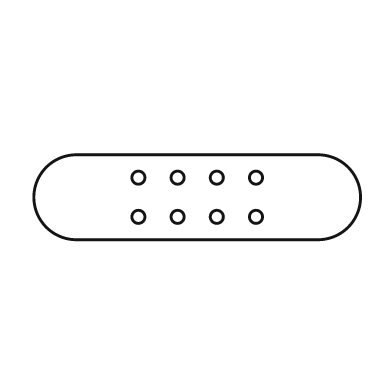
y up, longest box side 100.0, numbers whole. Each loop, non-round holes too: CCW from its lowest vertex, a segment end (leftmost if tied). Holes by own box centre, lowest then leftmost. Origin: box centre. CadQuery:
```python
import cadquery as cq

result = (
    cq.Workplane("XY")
    .moveTo(-37.0, -13.0)
    .lineTo(37.0, -13.0)
    .threePointArc((50.0, 0.0), (37.0, 13.0))
    .lineTo(-37.0, 13.0)
    .threePointArc((-50.0, 0.0), (-37.0, -13.0))
    .close()
    .moveTo(-18.0, -6.0)
    .circle(2.0)
    .moveTo(-6.0, -6.0)
    .circle(2.0)
    .moveTo(6.0, -6.0)
    .circle(2.0)
    .moveTo(18.0, -6.0)
    .circle(2.0)
    .moveTo(-18.0, 6.0)
    .circle(2.0)
    .moveTo(-6.0, 6.0)
    .circle(2.0)
    .moveTo(6.0, 6.0)
    .circle(2.0)
    .moveTo(18.0, 6.0)
    .circle(2.0)
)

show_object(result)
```